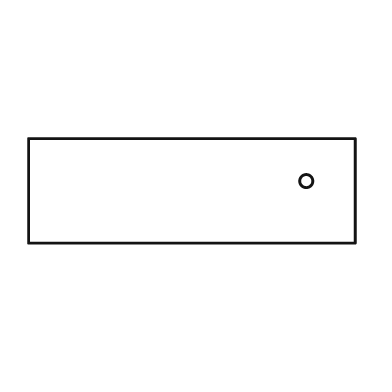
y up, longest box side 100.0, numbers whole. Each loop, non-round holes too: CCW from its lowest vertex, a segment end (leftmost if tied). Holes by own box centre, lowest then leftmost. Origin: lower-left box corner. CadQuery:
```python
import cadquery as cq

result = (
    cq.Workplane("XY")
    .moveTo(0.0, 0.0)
    .lineTo(100.0, 0.0)
    .lineTo(100.0, 32.0)
    .lineTo(0.0, 32.0)
    .close()
    .moveTo(85.0, 19.0)
    .circle(2.0)
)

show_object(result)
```